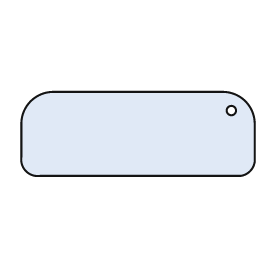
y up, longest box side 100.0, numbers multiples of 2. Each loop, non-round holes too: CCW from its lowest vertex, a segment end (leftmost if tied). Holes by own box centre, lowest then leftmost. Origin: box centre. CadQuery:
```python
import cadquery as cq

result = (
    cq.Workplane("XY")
    .moveTo(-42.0, -18.0)
    .lineTo(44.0, -18.0)
    .threePointArc((48.0, -16.0), (50.0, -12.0))
    .lineTo(50.0, 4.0)
    .threePointArc((46.0, 14.0), (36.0, 18.0))
    .lineTo(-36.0, 18.0)
    .threePointArc((-46.0, 14.0), (-50.0, 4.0))
    .lineTo(-50.0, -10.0)
    .threePointArc((-48.0, -16.0), (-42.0, -18.0))
    .close()
    .moveTo(40.0, 10.0)
    .circle(2.0)
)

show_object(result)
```